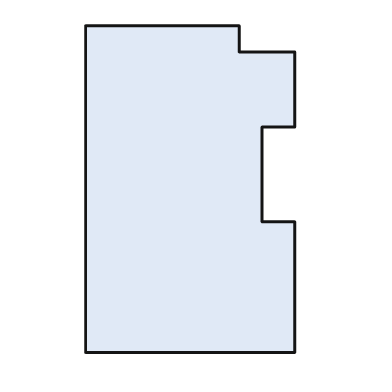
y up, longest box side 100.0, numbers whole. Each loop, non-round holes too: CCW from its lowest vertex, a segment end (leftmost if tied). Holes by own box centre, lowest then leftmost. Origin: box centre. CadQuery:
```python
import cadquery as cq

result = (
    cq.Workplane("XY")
    .moveTo(-32.0, -50.0)
    .lineTo(32.0, -50.0)
    .lineTo(32.0, -10.0)
    .lineTo(22.0, -10.0)
    .lineTo(22.0, 19.0)
    .lineTo(32.0, 19.0)
    .lineTo(32.0, 42.0)
    .lineTo(15.0, 42.0)
    .lineTo(15.0, 50.0)
    .lineTo(-32.0, 50.0)
    .close()
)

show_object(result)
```